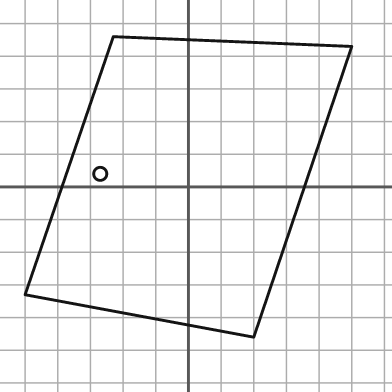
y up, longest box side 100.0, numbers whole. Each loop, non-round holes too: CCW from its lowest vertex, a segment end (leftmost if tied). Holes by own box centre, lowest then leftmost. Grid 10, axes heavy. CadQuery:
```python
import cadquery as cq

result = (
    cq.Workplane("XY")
    .moveTo(20.0, -46.0)
    .lineTo(50.0, 43.0)
    .lineTo(-23.0, 46.0)
    .lineTo(-50.0, -33.0)
    .close()
    .moveTo(-27.0, 4.0)
    .circle(2.0)
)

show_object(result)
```